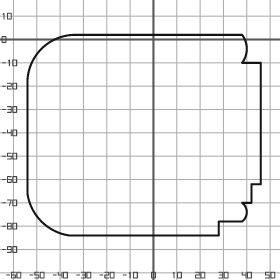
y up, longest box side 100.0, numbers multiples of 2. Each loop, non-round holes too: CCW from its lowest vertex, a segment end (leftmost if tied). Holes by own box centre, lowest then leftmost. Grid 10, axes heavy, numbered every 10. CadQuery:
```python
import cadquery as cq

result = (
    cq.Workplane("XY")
    .moveTo(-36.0, -84.0)
    .lineTo(28.0, -84.0)
    .lineTo(28.0, -78.0)
    .lineTo(38.0, -78.0)
    .threePointArc((40.0, -74.0), (38.0, -70.0))
    .lineTo(42.0, -70.0)
    .lineTo(42.0, -62.0)
    .lineTo(46.0, -62.0)
    .lineTo(46.0, -10.0)
    .lineTo(38.0, -10.0)
    .threePointArc((40.0, -4.0), (38.0, 2.0))
    .lineTo(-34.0, 2.0)
    .threePointArc((-48.0, -4.0), (-54.0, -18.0))
    .lineTo(-54.0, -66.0)
    .threePointArc((-48.0, -78.0), (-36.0, -84.0))
    .close()
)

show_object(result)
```